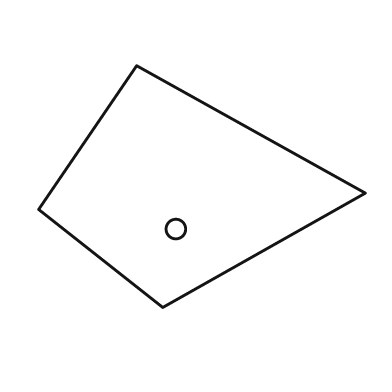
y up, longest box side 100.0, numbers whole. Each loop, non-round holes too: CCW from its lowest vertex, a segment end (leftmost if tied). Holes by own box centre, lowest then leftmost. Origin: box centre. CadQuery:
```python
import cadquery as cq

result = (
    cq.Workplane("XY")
    .moveTo(-12.0, -37.0)
    .lineTo(50.0, -2.0)
    .lineTo(-20.0, 37.0)
    .lineTo(-50.0, -7.0)
    .close()
    .moveTo(-8.0, -13.0)
    .circle(3.0)
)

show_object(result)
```